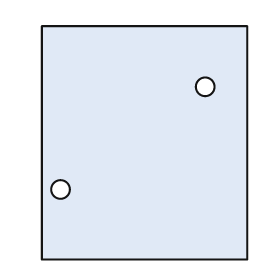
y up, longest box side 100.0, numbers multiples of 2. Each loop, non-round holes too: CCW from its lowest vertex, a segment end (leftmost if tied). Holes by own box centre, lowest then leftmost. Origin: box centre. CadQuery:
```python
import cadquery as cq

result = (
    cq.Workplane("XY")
    .moveTo(-44.0, -50.0)
    .lineTo(44.0, -50.0)
    .lineTo(44.0, 50.0)
    .lineTo(-44.0, 50.0)
    .close()
    .moveTo(-36.0, -20.0)
    .circle(4.0)
    .moveTo(26.0, 24.0)
    .circle(4.0)
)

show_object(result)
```